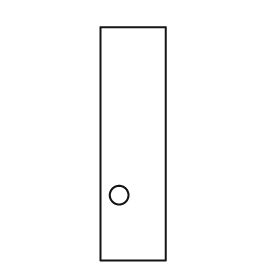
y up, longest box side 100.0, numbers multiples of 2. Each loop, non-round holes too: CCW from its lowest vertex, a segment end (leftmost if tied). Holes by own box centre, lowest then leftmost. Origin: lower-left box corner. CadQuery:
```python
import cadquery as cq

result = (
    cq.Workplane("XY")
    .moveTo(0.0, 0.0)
    .lineTo(28.0, 0.0)
    .lineTo(28.0, 100.0)
    .lineTo(0.0, 100.0)
    .close()
    .moveTo(8.0, 28.0)
    .circle(4.0)
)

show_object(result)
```